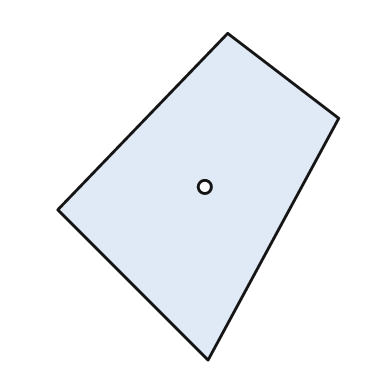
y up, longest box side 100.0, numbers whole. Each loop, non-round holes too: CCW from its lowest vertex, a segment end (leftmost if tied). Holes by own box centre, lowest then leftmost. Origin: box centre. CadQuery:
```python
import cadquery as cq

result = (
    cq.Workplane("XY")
    .moveTo(3.0, -50.0)
    .lineTo(43.0, 24.0)
    .lineTo(9.0, 50.0)
    .lineTo(-43.0, -4.0)
    .close()
    .moveTo(2.0, 3.0)
    .circle(2.0)
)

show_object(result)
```